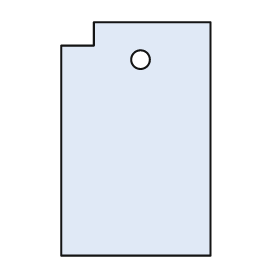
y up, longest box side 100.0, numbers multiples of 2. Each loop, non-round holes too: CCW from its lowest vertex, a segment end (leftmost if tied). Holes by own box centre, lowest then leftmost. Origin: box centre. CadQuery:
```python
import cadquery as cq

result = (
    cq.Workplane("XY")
    .moveTo(-32.0, -50.0)
    .lineTo(32.0, -50.0)
    .lineTo(32.0, 50.0)
    .lineTo(-18.0, 50.0)
    .lineTo(-18.0, 40.0)
    .lineTo(-32.0, 40.0)
    .close()
    .moveTo(2.0, 34.0)
    .circle(4.0)
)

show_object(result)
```